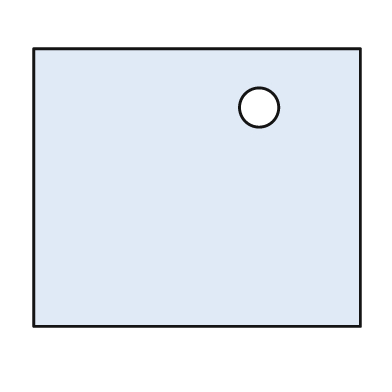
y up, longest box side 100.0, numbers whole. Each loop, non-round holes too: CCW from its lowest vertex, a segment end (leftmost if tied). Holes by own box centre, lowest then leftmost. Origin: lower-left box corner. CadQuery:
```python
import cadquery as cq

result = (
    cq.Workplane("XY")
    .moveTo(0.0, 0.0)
    .lineTo(100.0, 0.0)
    .lineTo(100.0, 85.0)
    .lineTo(0.0, 85.0)
    .close()
    .moveTo(69.0, 67.0)
    .circle(6.0)
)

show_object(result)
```